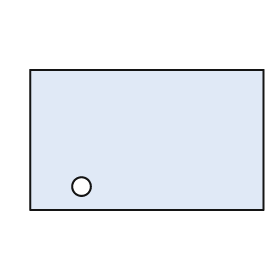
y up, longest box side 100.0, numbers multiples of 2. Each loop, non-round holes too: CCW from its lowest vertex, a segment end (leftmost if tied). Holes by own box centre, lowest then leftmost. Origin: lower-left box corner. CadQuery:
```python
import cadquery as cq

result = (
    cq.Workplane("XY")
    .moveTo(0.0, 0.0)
    .lineTo(100.0, 0.0)
    .lineTo(100.0, 60.0)
    .lineTo(0.0, 60.0)
    .close()
    .moveTo(22.0, 10.0)
    .circle(4.0)
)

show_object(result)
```